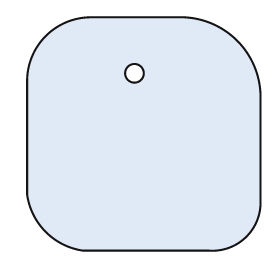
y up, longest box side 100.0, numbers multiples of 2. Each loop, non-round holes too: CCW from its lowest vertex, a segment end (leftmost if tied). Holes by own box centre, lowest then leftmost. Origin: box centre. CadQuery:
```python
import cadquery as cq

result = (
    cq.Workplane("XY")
    .moveTo(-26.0, -50.0)
    .lineTo(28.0, -50.0)
    .threePointArc((44.0, -44.0), (50.0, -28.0))
    .lineTo(50.0, 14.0)
    .threePointArc((40.0, 40.0), (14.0, 50.0))
    .lineTo(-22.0, 50.0)
    .threePointArc((-42.0, 42.0), (-50.0, 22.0))
    .lineTo(-50.0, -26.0)
    .threePointArc((-42.0, -42.0), (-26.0, -50.0))
    .close()
    .moveTo(-4.0, 26.0)
    .circle(4.0)
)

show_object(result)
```